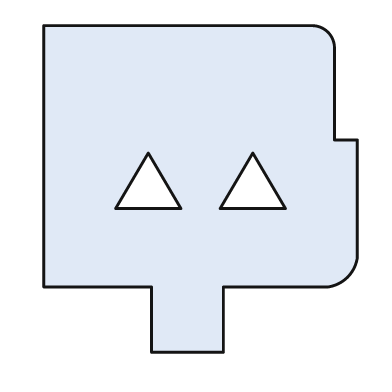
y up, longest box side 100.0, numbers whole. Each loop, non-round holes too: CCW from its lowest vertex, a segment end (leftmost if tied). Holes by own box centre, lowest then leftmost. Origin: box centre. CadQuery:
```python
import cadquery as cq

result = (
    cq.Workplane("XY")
    .moveTo(-15.0, -50.0)
    .lineTo(7.0, -50.0)
    .lineTo(7.0, -30.0)
    .lineTo(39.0, -30.0)
    .threePointArc((45.0, -27.0), (48.0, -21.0))
    .lineTo(48.0, 15.0)
    .lineTo(41.0, 15.0)
    .lineTo(41.0, 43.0)
    .threePointArc((39.0, 48.0), (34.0, 50.0))
    .lineTo(-48.0, 50.0)
    .lineTo(-48.0, -30.0)
    .lineTo(-15.0, -30.0)
    .close()
    .moveTo(-26.0, -6.0)
    .lineTo(-6.0, -6.0)
    .lineTo(-16.0, 11.0)
    .close()
    .moveTo(6.0, -6.0)
    .lineTo(26.0, -6.0)
    .lineTo(16.0, 11.0)
    .close()
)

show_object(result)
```